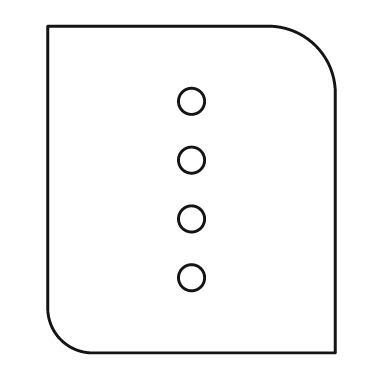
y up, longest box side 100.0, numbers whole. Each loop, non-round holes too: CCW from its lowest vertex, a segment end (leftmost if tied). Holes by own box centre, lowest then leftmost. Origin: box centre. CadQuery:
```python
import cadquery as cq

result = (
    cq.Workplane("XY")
    .moveTo(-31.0, -50.0)
    .lineTo(44.0, -50.0)
    .lineTo(44.0, 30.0)
    .threePointArc((38.0, 44.0), (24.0, 50.0))
    .lineTo(-44.0, 50.0)
    .lineTo(-44.0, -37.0)
    .threePointArc((-40.0, -46.0), (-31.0, -50.0))
    .close()
    .moveTo(0.0, -27.0)
    .circle(4.0)
    .moveTo(0.0, -9.0)
    .circle(4.0)
    .moveTo(0.0, 9.0)
    .circle(4.0)
    .moveTo(0.0, 27.0)
    .circle(4.0)
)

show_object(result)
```